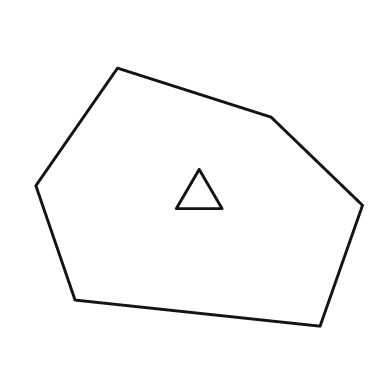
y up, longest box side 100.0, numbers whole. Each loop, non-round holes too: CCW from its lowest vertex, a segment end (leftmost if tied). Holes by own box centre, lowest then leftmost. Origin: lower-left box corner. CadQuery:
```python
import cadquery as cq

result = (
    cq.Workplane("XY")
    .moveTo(87.0, 0.0)
    .lineTo(100.0, 37.0)
    .lineTo(72.0, 64.0)
    .lineTo(25.0, 79.0)
    .lineTo(0.0, 43.0)
    .lineTo(12.0, 8.0)
    .close()
    .moveTo(43.0, 36.0)
    .lineTo(57.0, 36.0)
    .lineTo(50.0, 48.0)
    .close()
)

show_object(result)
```